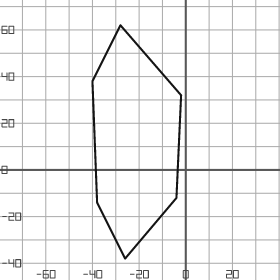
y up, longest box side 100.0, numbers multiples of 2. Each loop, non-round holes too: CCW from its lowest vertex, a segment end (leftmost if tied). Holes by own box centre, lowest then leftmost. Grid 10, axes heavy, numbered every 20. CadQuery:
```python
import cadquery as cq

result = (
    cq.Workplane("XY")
    .moveTo(-26.0, -38.0)
    .lineTo(-4.0, -12.0)
    .lineTo(-2.0, 32.0)
    .lineTo(-28.0, 62.0)
    .lineTo(-40.0, 38.0)
    .lineTo(-38.0, -14.0)
    .close()
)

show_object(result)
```